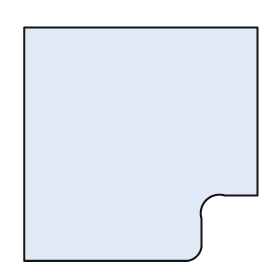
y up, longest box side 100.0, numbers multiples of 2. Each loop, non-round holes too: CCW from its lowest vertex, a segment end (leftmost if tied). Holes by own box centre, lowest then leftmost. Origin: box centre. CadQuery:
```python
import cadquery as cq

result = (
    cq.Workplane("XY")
    .moveTo(-50.0, -50.0)
    .lineTo(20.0, -50.0)
    .threePointArc((24.0, -48.0), (26.0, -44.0))
    .lineTo(26.0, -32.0)
    .threePointArc((28.0, -24.0), (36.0, -22.0))
    .lineTo(50.0, -22.0)
    .lineTo(50.0, 50.0)
    .lineTo(-50.0, 50.0)
    .close()
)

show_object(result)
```